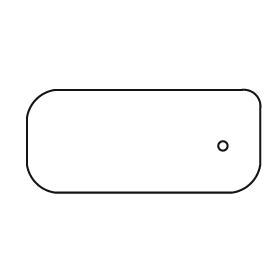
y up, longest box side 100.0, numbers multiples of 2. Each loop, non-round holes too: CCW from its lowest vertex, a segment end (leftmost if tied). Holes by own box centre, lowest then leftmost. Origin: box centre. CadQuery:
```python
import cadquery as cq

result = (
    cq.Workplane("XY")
    .moveTo(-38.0, -22.0)
    .lineTo(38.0, -22.0)
    .threePointArc((46.0, -18.0), (50.0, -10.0))
    .lineTo(50.0, 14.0)
    .threePointArc((48.0, 20.0), (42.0, 22.0))
    .lineTo(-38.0, 22.0)
    .threePointArc((-46.0, 18.0), (-50.0, 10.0))
    .lineTo(-50.0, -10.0)
    .threePointArc((-46.0, -18.0), (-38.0, -22.0))
    .close()
    .moveTo(34.0, -2.0)
    .circle(2.0)
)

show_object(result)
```